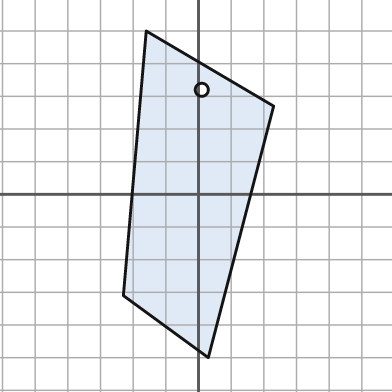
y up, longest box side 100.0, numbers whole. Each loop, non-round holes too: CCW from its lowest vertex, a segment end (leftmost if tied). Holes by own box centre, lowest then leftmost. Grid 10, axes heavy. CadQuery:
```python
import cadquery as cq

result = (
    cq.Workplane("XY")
    .moveTo(3.0, -50.0)
    .lineTo(23.0, 27.0)
    .lineTo(-16.0, 50.0)
    .lineTo(-23.0, -31.0)
    .close()
    .moveTo(1.0, 32.0)
    .circle(2.0)
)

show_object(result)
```